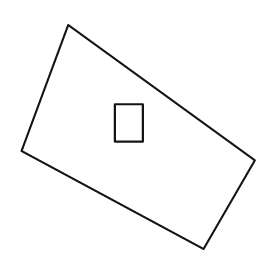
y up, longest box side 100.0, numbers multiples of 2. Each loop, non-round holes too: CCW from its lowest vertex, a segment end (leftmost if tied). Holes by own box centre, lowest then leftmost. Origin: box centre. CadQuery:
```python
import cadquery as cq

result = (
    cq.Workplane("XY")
    .moveTo(28.0, -48.0)
    .lineTo(50.0, -10.0)
    .lineTo(-30.0, 48.0)
    .lineTo(-50.0, -6.0)
    .close()
    .moveTo(-10.0, -2.0)
    .lineTo(2.0, -2.0)
    .lineTo(2.0, 14.0)
    .lineTo(-10.0, 14.0)
    .close()
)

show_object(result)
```